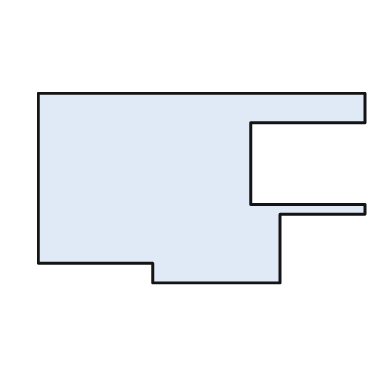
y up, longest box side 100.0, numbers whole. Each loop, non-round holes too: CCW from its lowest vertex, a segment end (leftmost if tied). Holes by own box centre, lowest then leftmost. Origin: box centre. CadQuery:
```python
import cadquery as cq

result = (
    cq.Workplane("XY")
    .moveTo(-15.0, -29.0)
    .lineTo(24.0, -29.0)
    .lineTo(24.0, -8.0)
    .lineTo(50.0, -8.0)
    .lineTo(50.0, -5.0)
    .lineTo(15.0, -5.0)
    .lineTo(15.0, 20.0)
    .lineTo(50.0, 20.0)
    .lineTo(50.0, 29.0)
    .lineTo(-50.0, 29.0)
    .lineTo(-50.0, -23.0)
    .lineTo(-15.0, -23.0)
    .close()
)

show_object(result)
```